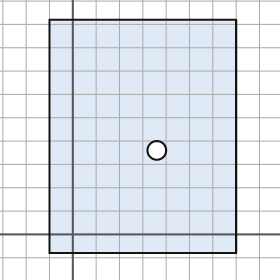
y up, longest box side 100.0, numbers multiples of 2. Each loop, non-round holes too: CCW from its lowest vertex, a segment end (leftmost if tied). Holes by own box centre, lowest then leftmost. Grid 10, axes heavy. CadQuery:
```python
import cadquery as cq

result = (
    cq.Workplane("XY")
    .moveTo(-10.0, -8.0)
    .lineTo(70.0, -8.0)
    .lineTo(70.0, 92.0)
    .lineTo(-10.0, 92.0)
    .close()
    .moveTo(36.0, 36.0)
    .circle(4.0)
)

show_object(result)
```